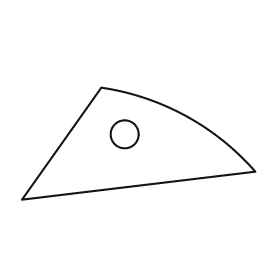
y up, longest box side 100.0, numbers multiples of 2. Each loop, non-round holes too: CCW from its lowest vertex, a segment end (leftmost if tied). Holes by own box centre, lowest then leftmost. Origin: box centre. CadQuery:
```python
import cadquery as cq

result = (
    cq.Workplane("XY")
    .moveTo(-50.0, -24.0)
    .lineTo(50.0, -12.0)
    .threePointArc((20.0, 12.0), (-16.0, 24.0))
    .close()
    .moveTo(-6.0, 4.0)
    .circle(6.0)
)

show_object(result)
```